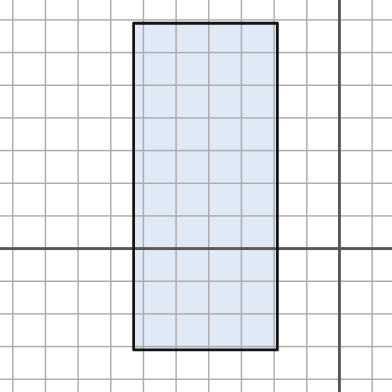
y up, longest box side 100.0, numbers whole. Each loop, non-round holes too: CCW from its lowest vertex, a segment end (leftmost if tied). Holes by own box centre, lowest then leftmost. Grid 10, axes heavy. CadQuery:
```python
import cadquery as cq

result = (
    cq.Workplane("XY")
    .moveTo(-63.0, -31.0)
    .lineTo(-19.0, -31.0)
    .lineTo(-19.0, 69.0)
    .lineTo(-63.0, 69.0)
    .close()
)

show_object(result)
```